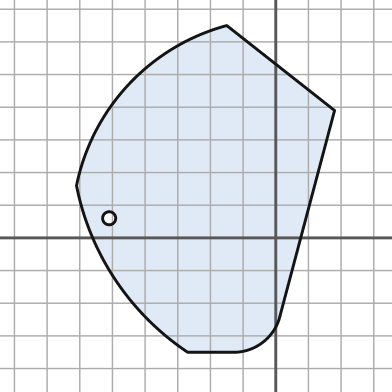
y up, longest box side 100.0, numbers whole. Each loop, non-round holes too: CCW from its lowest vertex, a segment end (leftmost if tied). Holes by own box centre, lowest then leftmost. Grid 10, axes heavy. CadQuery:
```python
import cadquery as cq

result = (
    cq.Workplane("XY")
    .moveTo(-27.0, -35.0)
    .lineTo(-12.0, -35.0)
    .threePointArc((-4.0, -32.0), (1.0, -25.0))
    .lineTo(18.0, 39.0)
    .lineTo(-15.0, 65.0)
    .threePointArc((-45.0, 47.0), (-61.0, 16.0))
    .threePointArc((-49.0, -13.0), (-27.0, -35.0))
    .close()
    .moveTo(-51.0, 6.0)
    .circle(2.0)
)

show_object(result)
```